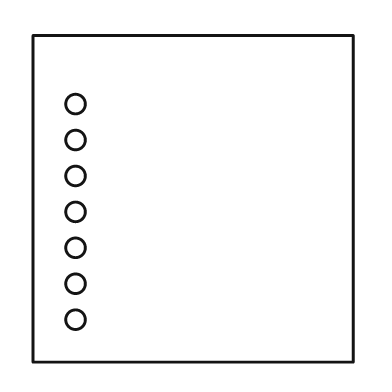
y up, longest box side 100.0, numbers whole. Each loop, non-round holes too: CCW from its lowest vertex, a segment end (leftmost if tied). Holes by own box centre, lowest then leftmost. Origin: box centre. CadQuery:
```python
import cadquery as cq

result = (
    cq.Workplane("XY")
    .moveTo(-49.0, -50.0)
    .lineTo(49.0, -50.0)
    .lineTo(49.0, 50.0)
    .lineTo(-49.0, 50.0)
    .close()
    .moveTo(-36.0, -37.0)
    .circle(3.0)
    .moveTo(-36.0, -26.0)
    .circle(3.0)
    .moveTo(-36.0, -15.0)
    .circle(3.0)
    .moveTo(-36.0, -4.0)
    .circle(3.0)
    .moveTo(-36.0, 7.0)
    .circle(3.0)
    .moveTo(-36.0, 18.0)
    .circle(3.0)
    .moveTo(-36.0, 29.0)
    .circle(3.0)
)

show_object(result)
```